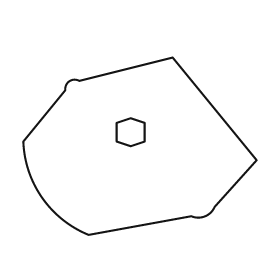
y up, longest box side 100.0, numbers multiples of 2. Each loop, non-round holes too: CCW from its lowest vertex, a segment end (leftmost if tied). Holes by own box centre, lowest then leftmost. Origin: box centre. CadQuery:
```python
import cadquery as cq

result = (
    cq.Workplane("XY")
    .moveTo(-22.0, -38.0)
    .lineTo(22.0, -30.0)
    .threePointArc((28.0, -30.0), (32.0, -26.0))
    .lineTo(50.0, -6.0)
    .lineTo(14.0, 38.0)
    .lineTo(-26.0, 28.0)
    .threePointArc((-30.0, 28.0), (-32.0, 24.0))
    .lineTo(-50.0, 2.0)
    .threePointArc((-42.0, -22.0), (-22.0, -38.0))
    .close()
    .moveTo(-4.0, 0.0)
    .lineTo(2.0, 2.0)
    .lineTo(2.0, 10.0)
    .lineTo(-4.0, 12.0)
    .lineTo(-10.0, 10.0)
    .lineTo(-10.0, 2.0)
    .close()
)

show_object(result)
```